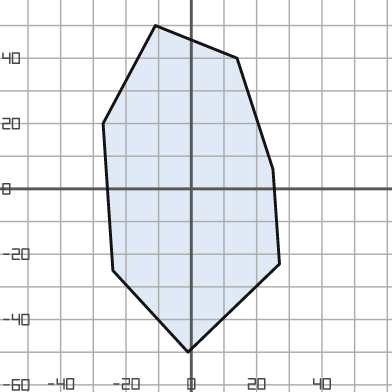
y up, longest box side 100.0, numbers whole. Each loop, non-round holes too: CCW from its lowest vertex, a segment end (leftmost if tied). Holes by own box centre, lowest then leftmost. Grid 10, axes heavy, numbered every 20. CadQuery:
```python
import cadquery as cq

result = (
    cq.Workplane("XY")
    .moveTo(-1.0, -50.0)
    .lineTo(27.0, -23.0)
    .lineTo(25.0, 6.0)
    .lineTo(14.0, 40.0)
    .lineTo(-11.0, 50.0)
    .lineTo(-27.0, 20.0)
    .lineTo(-24.0, -25.0)
    .close()
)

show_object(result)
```